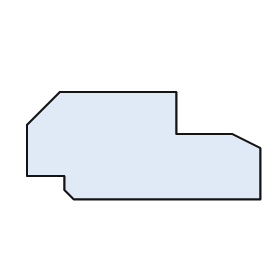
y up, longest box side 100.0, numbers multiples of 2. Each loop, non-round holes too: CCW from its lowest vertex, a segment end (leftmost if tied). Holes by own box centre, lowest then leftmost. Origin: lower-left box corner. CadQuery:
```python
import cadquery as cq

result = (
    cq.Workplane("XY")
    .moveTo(20.0, 0.0)
    .lineTo(100.0, 0.0)
    .lineTo(100.0, 22.0)
    .lineTo(88.0, 28.0)
    .lineTo(64.0, 28.0)
    .lineTo(64.0, 46.0)
    .lineTo(14.0, 46.0)
    .lineTo(0.0, 32.0)
    .lineTo(0.0, 10.0)
    .lineTo(16.0, 10.0)
    .lineTo(16.0, 4.0)
    .close()
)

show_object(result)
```